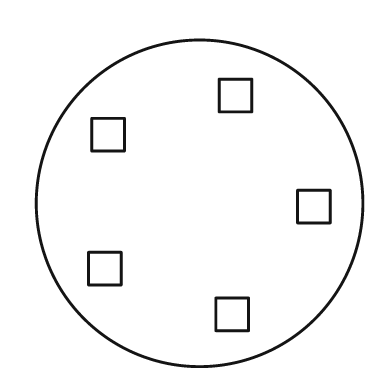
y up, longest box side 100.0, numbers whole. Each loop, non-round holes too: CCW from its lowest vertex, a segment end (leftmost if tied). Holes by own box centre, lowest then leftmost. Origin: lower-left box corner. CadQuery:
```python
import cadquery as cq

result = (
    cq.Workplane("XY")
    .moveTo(50.0, 50.0)
    .circle(50.0)
    .moveTo(55.0, 11.0)
    .lineTo(65.0, 11.0)
    .lineTo(65.0, 21.0)
    .lineTo(55.0, 21.0)
    .close()
    .moveTo(16.0, 25.0)
    .lineTo(26.0, 25.0)
    .lineTo(26.0, 35.0)
    .lineTo(16.0, 35.0)
    .close()
    .moveTo(80.0, 44.0)
    .lineTo(90.0, 44.0)
    .lineTo(90.0, 54.0)
    .lineTo(80.0, 54.0)
    .close()
    .moveTo(17.0, 66.0)
    .lineTo(27.0, 66.0)
    .lineTo(27.0, 76.0)
    .lineTo(17.0, 76.0)
    .close()
    .moveTo(56.0, 78.0)
    .lineTo(66.0, 78.0)
    .lineTo(66.0, 88.0)
    .lineTo(56.0, 88.0)
    .close()
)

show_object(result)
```